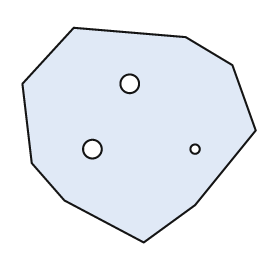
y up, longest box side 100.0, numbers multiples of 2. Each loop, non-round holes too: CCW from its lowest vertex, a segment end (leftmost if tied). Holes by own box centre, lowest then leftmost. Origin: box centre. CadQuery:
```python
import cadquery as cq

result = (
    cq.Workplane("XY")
    .moveTo(2.0, -46.0)
    .lineTo(24.0, -30.0)
    .lineTo(50.0, 2.0)
    .lineTo(40.0, 30.0)
    .lineTo(20.0, 42.0)
    .lineTo(-28.0, 46.0)
    .lineTo(-50.0, 22.0)
    .lineTo(-46.0, -12.0)
    .lineTo(-32.0, -28.0)
    .close()
    .moveTo(-20.0, -6.0)
    .circle(4.0)
    .moveTo(24.0, -6.0)
    .circle(2.0)
    .moveTo(-4.0, 22.0)
    .circle(4.0)
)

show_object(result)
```